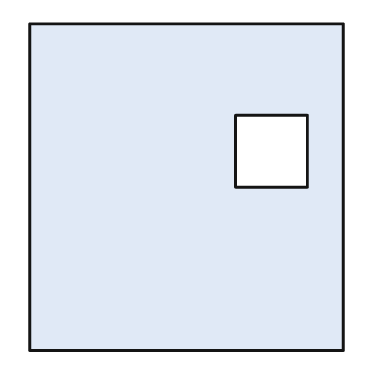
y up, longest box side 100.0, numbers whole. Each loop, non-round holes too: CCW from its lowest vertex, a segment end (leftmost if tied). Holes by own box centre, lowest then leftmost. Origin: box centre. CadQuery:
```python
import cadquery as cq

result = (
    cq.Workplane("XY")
    .moveTo(-48.0, -50.0)
    .lineTo(48.0, -50.0)
    .lineTo(48.0, 50.0)
    .lineTo(-48.0, 50.0)
    .close()
    .moveTo(15.0, 0.0)
    .lineTo(37.0, 0.0)
    .lineTo(37.0, 22.0)
    .lineTo(15.0, 22.0)
    .close()
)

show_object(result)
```